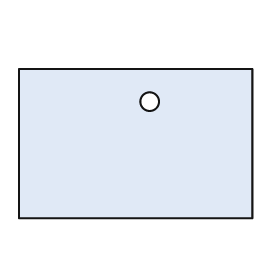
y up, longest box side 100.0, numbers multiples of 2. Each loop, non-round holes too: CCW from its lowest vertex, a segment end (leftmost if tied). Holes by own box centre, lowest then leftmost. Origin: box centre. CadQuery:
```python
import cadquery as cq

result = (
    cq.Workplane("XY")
    .moveTo(-50.0, -32.0)
    .lineTo(50.0, -32.0)
    .lineTo(50.0, 32.0)
    .lineTo(-50.0, 32.0)
    .close()
    .moveTo(6.0, 18.0)
    .circle(4.0)
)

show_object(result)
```